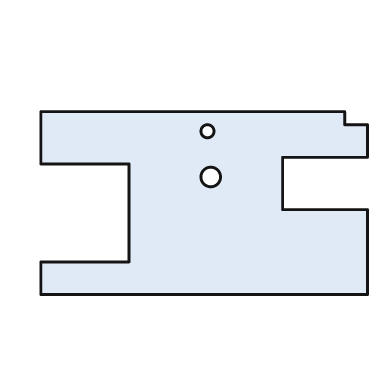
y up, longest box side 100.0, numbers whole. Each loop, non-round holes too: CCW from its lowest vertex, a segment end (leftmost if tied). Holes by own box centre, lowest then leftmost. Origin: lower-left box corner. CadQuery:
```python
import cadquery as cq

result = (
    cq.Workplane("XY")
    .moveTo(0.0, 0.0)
    .lineTo(100.0, 0.0)
    .lineTo(100.0, 26.0)
    .lineTo(74.0, 26.0)
    .lineTo(74.0, 42.0)
    .lineTo(100.0, 42.0)
    .lineTo(100.0, 52.0)
    .lineTo(93.0, 52.0)
    .lineTo(93.0, 56.0)
    .lineTo(0.0, 56.0)
    .lineTo(0.0, 40.0)
    .lineTo(27.0, 40.0)
    .lineTo(27.0, 10.0)
    .lineTo(0.0, 10.0)
    .close()
    .moveTo(52.0, 36.0)
    .circle(3.0)
    .moveTo(51.0, 50.0)
    .circle(2.0)
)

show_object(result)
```